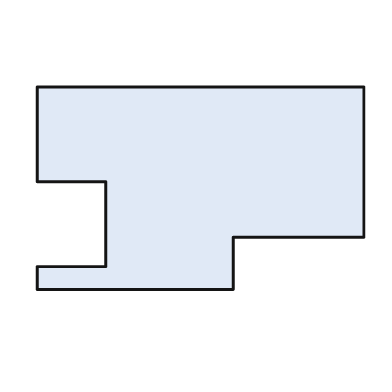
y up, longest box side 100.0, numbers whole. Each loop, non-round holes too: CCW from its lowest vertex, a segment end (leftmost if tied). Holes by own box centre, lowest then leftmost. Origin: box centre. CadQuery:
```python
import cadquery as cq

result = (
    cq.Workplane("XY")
    .moveTo(-50.0, -31.0)
    .lineTo(10.0, -31.0)
    .lineTo(10.0, -15.0)
    .lineTo(50.0, -15.0)
    .lineTo(50.0, 31.0)
    .lineTo(-50.0, 31.0)
    .lineTo(-50.0, 2.0)
    .lineTo(-29.0, 2.0)
    .lineTo(-29.0, -24.0)
    .lineTo(-50.0, -24.0)
    .close()
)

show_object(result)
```